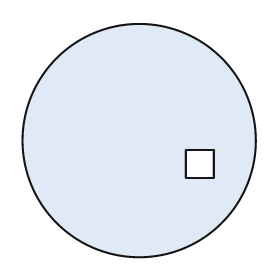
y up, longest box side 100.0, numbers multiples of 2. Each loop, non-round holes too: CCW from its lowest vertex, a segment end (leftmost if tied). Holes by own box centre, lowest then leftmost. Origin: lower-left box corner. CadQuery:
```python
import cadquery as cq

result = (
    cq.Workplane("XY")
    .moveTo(50.0, 50.0)
    .circle(50.0)
    .moveTo(70.0, 34.0)
    .lineTo(82.0, 34.0)
    .lineTo(82.0, 46.0)
    .lineTo(70.0, 46.0)
    .close()
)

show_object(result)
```